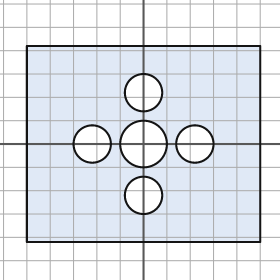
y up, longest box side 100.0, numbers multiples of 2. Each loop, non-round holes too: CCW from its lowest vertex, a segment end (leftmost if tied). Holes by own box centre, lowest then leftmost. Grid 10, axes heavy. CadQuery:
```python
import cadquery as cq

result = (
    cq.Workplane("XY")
    .moveTo(-50.0, -42.0)
    .lineTo(50.0, -42.0)
    .lineTo(50.0, 42.0)
    .lineTo(-50.0, 42.0)
    .close()
    .moveTo(0.0, -22.0)
    .circle(8.0)
    .moveTo(-22.0, 0.0)
    .circle(8.0)
    .moveTo(0.0, 0.0)
    .circle(10.0)
    .moveTo(22.0, 0.0)
    .circle(8.0)
    .moveTo(0.0, 22.0)
    .circle(8.0)
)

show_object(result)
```